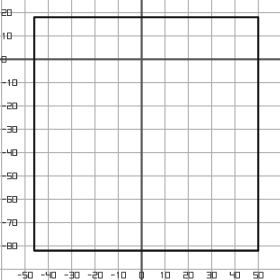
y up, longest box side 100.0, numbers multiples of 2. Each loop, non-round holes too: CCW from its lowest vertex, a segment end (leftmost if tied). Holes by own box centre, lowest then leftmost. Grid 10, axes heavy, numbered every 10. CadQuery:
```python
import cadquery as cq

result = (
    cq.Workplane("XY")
    .moveTo(-46.0, -82.0)
    .lineTo(50.0, -82.0)
    .lineTo(50.0, 18.0)
    .lineTo(-46.0, 18.0)
    .close()
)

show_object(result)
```